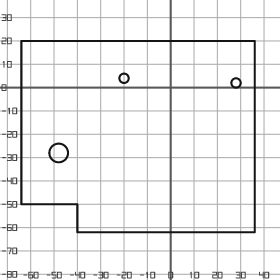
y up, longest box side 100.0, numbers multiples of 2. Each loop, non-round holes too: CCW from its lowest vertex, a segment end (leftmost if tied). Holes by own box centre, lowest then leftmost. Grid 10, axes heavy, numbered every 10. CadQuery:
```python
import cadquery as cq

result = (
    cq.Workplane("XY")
    .moveTo(-40.0, -62.0)
    .lineTo(36.0, -62.0)
    .lineTo(36.0, 20.0)
    .lineTo(-64.0, 20.0)
    .lineTo(-64.0, -50.0)
    .lineTo(-40.0, -50.0)
    .close()
    .moveTo(-48.0, -28.0)
    .circle(4.0)
    .moveTo(28.0, 2.0)
    .circle(2.0)
    .moveTo(-20.0, 4.0)
    .circle(2.0)
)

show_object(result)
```